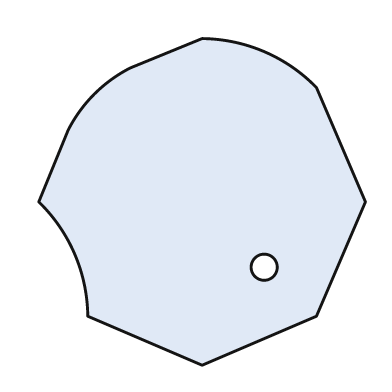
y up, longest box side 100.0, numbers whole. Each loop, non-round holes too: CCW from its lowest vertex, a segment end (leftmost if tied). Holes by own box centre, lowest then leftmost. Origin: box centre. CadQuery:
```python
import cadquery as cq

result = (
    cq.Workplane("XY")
    .moveTo(0.0, -50.0)
    .lineTo(35.0, -35.0)
    .lineTo(50.0, 0.0)
    .lineTo(35.0, 35.0)
    .threePointArc((19.0, 46.0), (0.0, 50.0))
    .lineTo(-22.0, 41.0)
    .threePointArc((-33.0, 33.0), (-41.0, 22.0))
    .lineTo(-50.0, 0.0)
    .threePointArc((-39.0, -16.0), (-35.0, -35.0))
    .close()
    .moveTo(19.0, -20.0)
    .circle(4.0)
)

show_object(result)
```